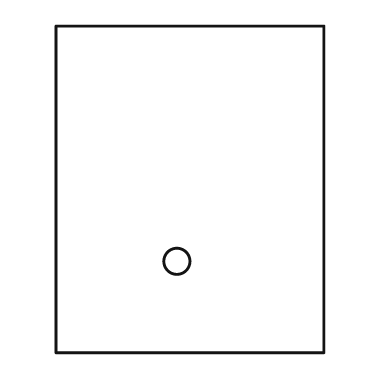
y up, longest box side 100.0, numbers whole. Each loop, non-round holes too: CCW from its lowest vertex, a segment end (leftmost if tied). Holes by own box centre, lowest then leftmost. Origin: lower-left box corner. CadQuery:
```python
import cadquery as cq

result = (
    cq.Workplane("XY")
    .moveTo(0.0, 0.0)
    .lineTo(82.0, 0.0)
    .lineTo(82.0, 100.0)
    .lineTo(0.0, 100.0)
    .close()
    .moveTo(37.0, 28.0)
    .circle(4.0)
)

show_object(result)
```